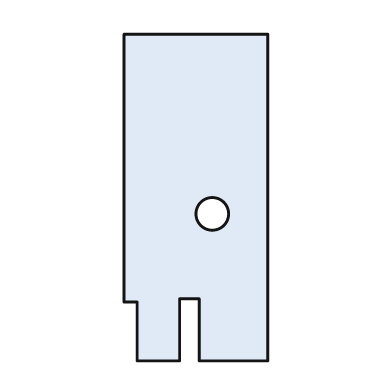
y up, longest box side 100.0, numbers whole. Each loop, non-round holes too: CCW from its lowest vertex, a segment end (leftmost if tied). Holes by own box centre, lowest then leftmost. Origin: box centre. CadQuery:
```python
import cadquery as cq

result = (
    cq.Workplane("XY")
    .moveTo(-18.0, -50.0)
    .lineTo(-5.0, -50.0)
    .lineTo(-5.0, -31.0)
    .lineTo(1.0, -31.0)
    .lineTo(1.0, -50.0)
    .lineTo(22.0, -50.0)
    .lineTo(22.0, 50.0)
    .lineTo(-22.0, 50.0)
    .lineTo(-22.0, -32.0)
    .lineTo(-18.0, -32.0)
    .close()
    .moveTo(5.0, -5.0)
    .circle(5.0)
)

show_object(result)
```